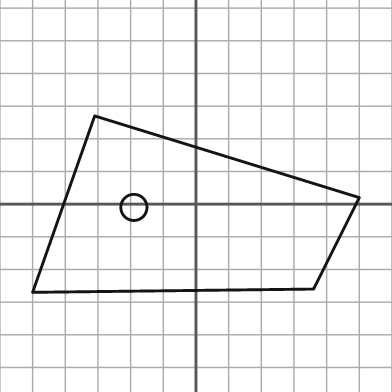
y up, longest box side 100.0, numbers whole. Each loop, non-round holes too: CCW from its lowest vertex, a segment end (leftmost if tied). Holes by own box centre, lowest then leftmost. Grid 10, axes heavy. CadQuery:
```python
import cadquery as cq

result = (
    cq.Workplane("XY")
    .moveTo(-50.0, -27.0)
    .lineTo(36.0, -26.0)
    .lineTo(50.0, 2.0)
    .lineTo(-31.0, 27.0)
    .close()
    .moveTo(-19.0, -1.0)
    .circle(4.0)
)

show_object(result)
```